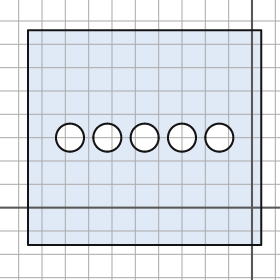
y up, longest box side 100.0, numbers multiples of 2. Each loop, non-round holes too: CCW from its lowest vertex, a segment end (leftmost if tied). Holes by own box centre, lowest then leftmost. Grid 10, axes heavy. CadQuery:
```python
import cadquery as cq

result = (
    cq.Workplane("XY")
    .moveTo(-96.0, -16.0)
    .lineTo(4.0, -16.0)
    .lineTo(4.0, 76.0)
    .lineTo(-96.0, 76.0)
    .close()
    .moveTo(-78.0, 30.0)
    .circle(6.0)
    .moveTo(-62.0, 30.0)
    .circle(6.0)
    .moveTo(-46.0, 30.0)
    .circle(6.0)
    .moveTo(-30.0, 30.0)
    .circle(6.0)
    .moveTo(-14.0, 30.0)
    .circle(6.0)
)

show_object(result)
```